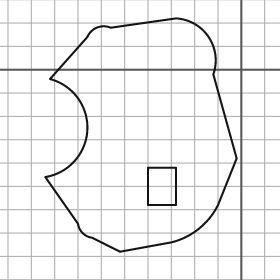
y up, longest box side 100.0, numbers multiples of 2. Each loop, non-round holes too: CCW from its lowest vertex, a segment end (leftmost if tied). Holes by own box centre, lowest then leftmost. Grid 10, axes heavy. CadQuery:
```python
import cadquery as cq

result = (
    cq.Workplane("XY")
    .moveTo(-52.0, -78.0)
    .lineTo(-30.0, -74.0)
    .threePointArc((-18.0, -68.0), (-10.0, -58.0))
    .lineTo(-2.0, -38.0)
    .lineTo(-12.0, -2.0)
    .threePointArc((-14.0, 14.0), (-28.0, 22.0))
    .lineTo(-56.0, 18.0)
    .threePointArc((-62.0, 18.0), (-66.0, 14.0))
    .lineTo(-82.0, -4.0)
    .threePointArc((-66.0, -26.0), (-84.0, -46.0))
    .lineTo(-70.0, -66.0)
    .threePointArc((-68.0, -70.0), (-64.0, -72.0))
    .close()
    .moveTo(-40.0, -58.0)
    .lineTo(-28.0, -58.0)
    .lineTo(-28.0, -42.0)
    .lineTo(-40.0, -42.0)
    .close()
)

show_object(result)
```